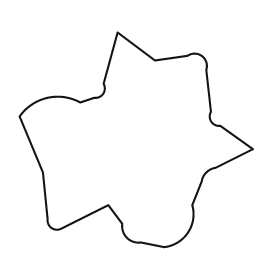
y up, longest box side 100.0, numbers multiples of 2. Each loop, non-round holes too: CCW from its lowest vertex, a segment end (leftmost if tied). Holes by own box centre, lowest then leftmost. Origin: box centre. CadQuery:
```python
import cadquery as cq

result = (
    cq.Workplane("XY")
    .moveTo(12.0, -46.0)
    .threePointArc((22.0, -40.0), (24.0, -28.0))
    .lineTo(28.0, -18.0)
    .threePointArc((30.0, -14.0), (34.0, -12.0))
    .lineTo(50.0, -4.0)
    .lineTo(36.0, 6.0)
    .threePointArc((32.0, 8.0), (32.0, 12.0))
    .lineTo(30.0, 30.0)
    .threePointArc((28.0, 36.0), (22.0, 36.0))
    .lineTo(8.0, 34.0)
    .lineTo(-8.0, 46.0)
    .lineTo(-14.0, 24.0)
    .threePointArc((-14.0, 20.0), (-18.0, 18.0))
    .lineTo(-24.0, 16.0)
    .threePointArc((-38.0, 18.0), (-50.0, 10.0))
    .lineTo(-40.0, -14.0)
    .lineTo(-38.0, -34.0)
    .threePointArc((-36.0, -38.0), (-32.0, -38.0))
    .lineTo(-12.0, -28.0)
    .lineTo(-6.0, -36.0)
    .threePointArc((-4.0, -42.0), (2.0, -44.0))
    .close()
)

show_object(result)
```